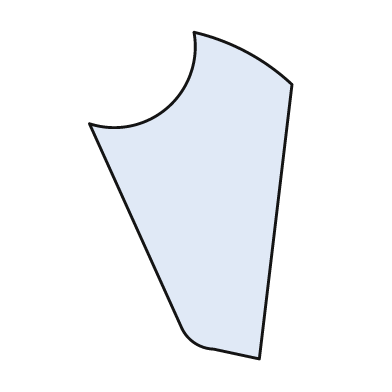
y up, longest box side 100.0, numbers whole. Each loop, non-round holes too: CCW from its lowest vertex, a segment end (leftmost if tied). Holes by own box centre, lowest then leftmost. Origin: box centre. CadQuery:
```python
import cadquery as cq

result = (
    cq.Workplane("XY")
    .moveTo(21.0, -50.0)
    .lineTo(31.0, 34.0)
    .threePointArc((17.0, 44.0), (1.0, 50.0))
    .threePointArc((-7.0, 27.0), (-31.0, 22.0))
    .lineTo(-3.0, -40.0)
    .threePointArc((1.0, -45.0), (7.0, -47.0))
    .close()
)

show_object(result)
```